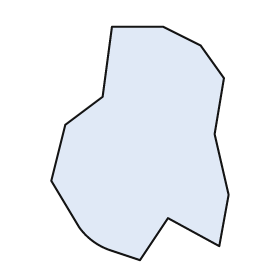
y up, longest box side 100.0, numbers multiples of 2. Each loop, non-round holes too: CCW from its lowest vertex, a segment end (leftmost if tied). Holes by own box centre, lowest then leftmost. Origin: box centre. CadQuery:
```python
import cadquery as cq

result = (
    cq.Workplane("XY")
    .moveTo(0.0, -50.0)
    .lineTo(12.0, -32.0)
    .lineTo(34.0, -44.0)
    .lineTo(38.0, -22.0)
    .lineTo(32.0, 4.0)
    .lineTo(36.0, 28.0)
    .lineTo(26.0, 42.0)
    .lineTo(10.0, 50.0)
    .lineTo(-12.0, 50.0)
    .lineTo(-16.0, 20.0)
    .lineTo(-32.0, 8.0)
    .lineTo(-38.0, -16.0)
    .lineTo(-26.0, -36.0)
    .threePointArc((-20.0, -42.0), (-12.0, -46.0))
    .close()
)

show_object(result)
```